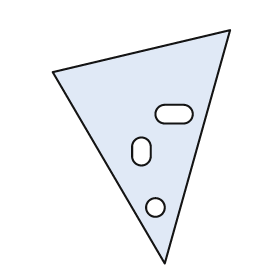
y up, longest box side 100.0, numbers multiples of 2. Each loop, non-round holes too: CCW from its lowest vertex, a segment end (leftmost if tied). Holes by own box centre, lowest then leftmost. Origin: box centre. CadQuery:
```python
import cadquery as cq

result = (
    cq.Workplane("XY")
    .moveTo(10.0, -50.0)
    .lineTo(38.0, 50.0)
    .lineTo(-38.0, 32.0)
    .close()
    .moveTo(6.0, -26.0)
    .circle(4.0)
    .moveTo(-4.0, -4.0)
    .threePointArc((0.0, -8.0), (4.0, -4.0))
    .lineTo(4.0, 0.0)
    .threePointArc((0.0, 4.0), (-4.0, 0.0))
    .close()
    .moveTo(10.0, 10.0)
    .lineTo(18.0, 10.0)
    .threePointArc((22.0, 14.0), (18.0, 18.0))
    .lineTo(10.0, 18.0)
    .threePointArc((6.0, 14.0), (10.0, 10.0))
    .close()
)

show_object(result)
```